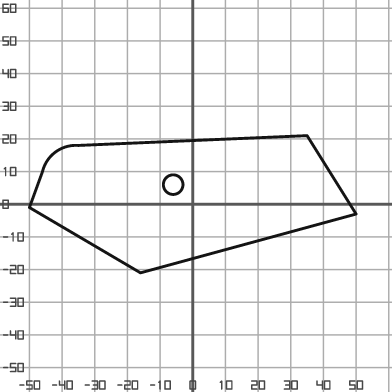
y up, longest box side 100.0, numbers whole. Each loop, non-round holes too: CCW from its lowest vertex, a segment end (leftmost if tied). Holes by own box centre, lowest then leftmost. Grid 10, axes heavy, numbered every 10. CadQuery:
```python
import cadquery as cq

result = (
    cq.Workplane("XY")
    .moveTo(-16.0, -21.0)
    .lineTo(50.0, -3.0)
    .lineTo(35.0, 21.0)
    .lineTo(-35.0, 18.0)
    .threePointArc((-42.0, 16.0), (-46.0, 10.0))
    .lineTo(-50.0, -1.0)
    .close()
    .moveTo(-6.0, 6.0)
    .circle(3.0)
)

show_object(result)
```